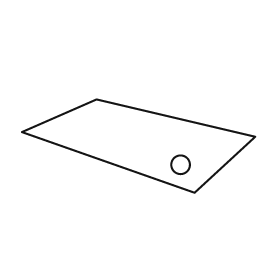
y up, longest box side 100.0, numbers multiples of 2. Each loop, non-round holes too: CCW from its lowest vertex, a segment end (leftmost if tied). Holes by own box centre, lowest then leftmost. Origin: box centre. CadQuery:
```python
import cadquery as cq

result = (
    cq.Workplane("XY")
    .moveTo(24.0, -20.0)
    .lineTo(50.0, 4.0)
    .lineTo(-18.0, 20.0)
    .lineTo(-50.0, 6.0)
    .close()
    .moveTo(18.0, -8.0)
    .circle(4.0)
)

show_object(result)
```